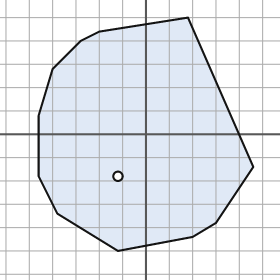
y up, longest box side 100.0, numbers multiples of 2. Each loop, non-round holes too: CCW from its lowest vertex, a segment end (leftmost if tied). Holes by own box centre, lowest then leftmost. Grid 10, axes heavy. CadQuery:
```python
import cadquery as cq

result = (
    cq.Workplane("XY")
    .moveTo(-12.0, -50.0)
    .lineTo(20.0, -44.0)
    .lineTo(30.0, -38.0)
    .lineTo(46.0, -14.0)
    .lineTo(18.0, 50.0)
    .lineTo(-20.0, 44.0)
    .lineTo(-28.0, 40.0)
    .lineTo(-40.0, 28.0)
    .lineTo(-46.0, 8.0)
    .lineTo(-46.0, -18.0)
    .lineTo(-38.0, -34.0)
    .close()
    .moveTo(-12.0, -18.0)
    .circle(2.0)
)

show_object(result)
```